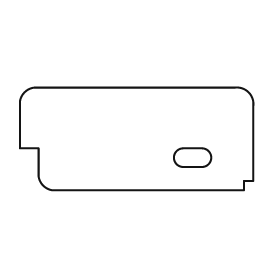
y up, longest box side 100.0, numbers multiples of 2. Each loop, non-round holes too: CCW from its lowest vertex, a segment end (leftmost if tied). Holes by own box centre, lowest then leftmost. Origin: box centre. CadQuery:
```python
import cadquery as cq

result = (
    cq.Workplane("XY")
    .moveTo(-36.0, -22.0)
    .lineTo(46.0, -22.0)
    .lineTo(46.0, -18.0)
    .lineTo(50.0, -18.0)
    .lineTo(50.0, 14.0)
    .threePointArc((48.0, 20.0), (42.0, 22.0))
    .lineTo(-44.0, 22.0)
    .threePointArc((-48.0, 20.0), (-50.0, 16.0))
    .lineTo(-50.0, -4.0)
    .lineTo(-42.0, -4.0)
    .lineTo(-42.0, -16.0)
    .threePointArc((-40.0, -20.0), (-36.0, -22.0))
    .close()
    .moveTo(20.0, -12.0)
    .lineTo(28.0, -12.0)
    .threePointArc((32.0, -8.0), (28.0, -4.0))
    .lineTo(20.0, -4.0)
    .threePointArc((16.0, -8.0), (20.0, -12.0))
    .close()
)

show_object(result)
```